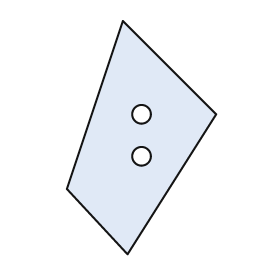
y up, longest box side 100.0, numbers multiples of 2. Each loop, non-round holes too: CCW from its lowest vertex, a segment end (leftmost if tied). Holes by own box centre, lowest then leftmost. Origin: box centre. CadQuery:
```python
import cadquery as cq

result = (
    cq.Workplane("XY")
    .moveTo(-6.0, -50.0)
    .lineTo(32.0, 10.0)
    .lineTo(-8.0, 50.0)
    .lineTo(-32.0, -22.0)
    .close()
    .moveTo(0.0, -8.0)
    .circle(4.0)
    .moveTo(0.0, 10.0)
    .circle(4.0)
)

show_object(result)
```